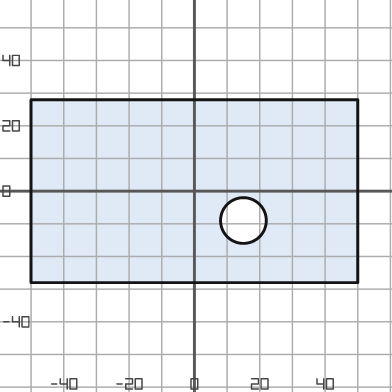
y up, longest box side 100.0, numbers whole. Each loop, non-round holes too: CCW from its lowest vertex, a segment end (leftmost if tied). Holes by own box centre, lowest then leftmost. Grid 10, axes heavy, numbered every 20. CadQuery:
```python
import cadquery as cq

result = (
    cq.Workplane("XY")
    .moveTo(-50.0, -28.0)
    .lineTo(50.0, -28.0)
    .lineTo(50.0, 28.0)
    .lineTo(-50.0, 28.0)
    .close()
    .moveTo(15.0, -9.0)
    .circle(7.0)
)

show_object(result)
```